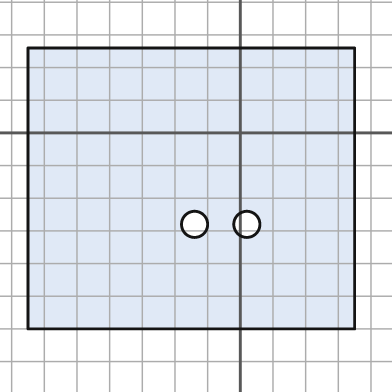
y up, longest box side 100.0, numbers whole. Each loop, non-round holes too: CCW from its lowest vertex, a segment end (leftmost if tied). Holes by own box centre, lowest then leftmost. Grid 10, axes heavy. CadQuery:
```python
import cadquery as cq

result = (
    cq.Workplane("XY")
    .moveTo(-65.0, -60.0)
    .lineTo(35.0, -60.0)
    .lineTo(35.0, 26.0)
    .lineTo(-65.0, 26.0)
    .close()
    .moveTo(-14.0, -28.0)
    .circle(4.0)
    .moveTo(2.0, -28.0)
    .circle(4.0)
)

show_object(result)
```